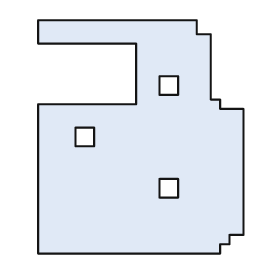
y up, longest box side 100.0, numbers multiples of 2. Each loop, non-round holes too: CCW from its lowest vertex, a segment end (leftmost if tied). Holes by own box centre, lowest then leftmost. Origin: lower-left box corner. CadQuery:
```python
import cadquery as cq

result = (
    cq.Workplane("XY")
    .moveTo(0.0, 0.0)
    .lineTo(78.0, 0.0)
    .lineTo(78.0, 4.0)
    .lineTo(82.0, 4.0)
    .lineTo(82.0, 8.0)
    .lineTo(88.0, 8.0)
    .lineTo(88.0, 62.0)
    .lineTo(78.0, 62.0)
    .lineTo(78.0, 66.0)
    .lineTo(74.0, 66.0)
    .lineTo(74.0, 94.0)
    .lineTo(68.0, 94.0)
    .lineTo(68.0, 100.0)
    .lineTo(0.0, 100.0)
    .lineTo(0.0, 90.0)
    .lineTo(42.0, 90.0)
    .lineTo(42.0, 64.0)
    .lineTo(0.0, 64.0)
    .close()
    .moveTo(52.0, 24.0)
    .lineTo(60.0, 24.0)
    .lineTo(60.0, 32.0)
    .lineTo(52.0, 32.0)
    .close()
    .moveTo(16.0, 46.0)
    .lineTo(24.0, 46.0)
    .lineTo(24.0, 54.0)
    .lineTo(16.0, 54.0)
    .close()
    .moveTo(52.0, 68.0)
    .lineTo(60.0, 68.0)
    .lineTo(60.0, 76.0)
    .lineTo(52.0, 76.0)
    .close()
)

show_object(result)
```